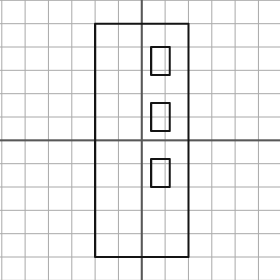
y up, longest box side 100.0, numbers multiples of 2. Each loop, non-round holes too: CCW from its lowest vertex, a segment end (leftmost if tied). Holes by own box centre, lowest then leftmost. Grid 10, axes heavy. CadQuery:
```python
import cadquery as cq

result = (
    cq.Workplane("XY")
    .moveTo(-20.0, -50.0)
    .lineTo(20.0, -50.0)
    .lineTo(20.0, 50.0)
    .lineTo(-20.0, 50.0)
    .close()
    .moveTo(4.0, -20.0)
    .lineTo(12.0, -20.0)
    .lineTo(12.0, -8.0)
    .lineTo(4.0, -8.0)
    .close()
    .moveTo(4.0, 4.0)
    .lineTo(12.0, 4.0)
    .lineTo(12.0, 16.0)
    .lineTo(4.0, 16.0)
    .close()
    .moveTo(4.0, 28.0)
    .lineTo(12.0, 28.0)
    .lineTo(12.0, 40.0)
    .lineTo(4.0, 40.0)
    .close()
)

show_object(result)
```